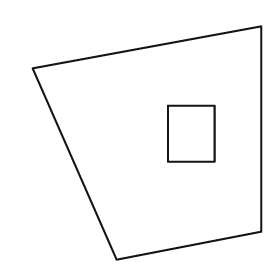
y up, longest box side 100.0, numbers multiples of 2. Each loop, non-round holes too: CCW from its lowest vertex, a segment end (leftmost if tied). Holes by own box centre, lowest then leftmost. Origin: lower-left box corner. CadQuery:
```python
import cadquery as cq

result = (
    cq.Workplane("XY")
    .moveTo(36.0, 0.0)
    .lineTo(98.0, 12.0)
    .lineTo(98.0, 100.0)
    .lineTo(0.0, 82.0)
    .close()
    .moveTo(58.0, 42.0)
    .lineTo(78.0, 42.0)
    .lineTo(78.0, 66.0)
    .lineTo(58.0, 66.0)
    .close()
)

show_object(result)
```